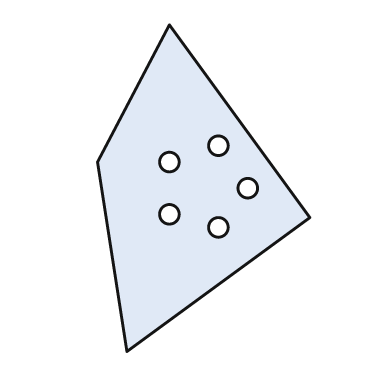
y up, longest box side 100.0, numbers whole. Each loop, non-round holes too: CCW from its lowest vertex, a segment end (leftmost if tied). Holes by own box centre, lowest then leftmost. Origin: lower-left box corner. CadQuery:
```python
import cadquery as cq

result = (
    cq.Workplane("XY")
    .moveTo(9.0, 0.0)
    .lineTo(65.0, 41.0)
    .lineTo(22.0, 100.0)
    .lineTo(0.0, 58.0)
    .close()
    .moveTo(37.0, 38.0)
    .circle(3.0)
    .moveTo(22.0, 42.0)
    .circle(3.0)
    .moveTo(46.0, 50.0)
    .circle(3.0)
    .moveTo(22.0, 58.0)
    .circle(3.0)
    .moveTo(37.0, 63.0)
    .circle(3.0)
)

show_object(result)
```